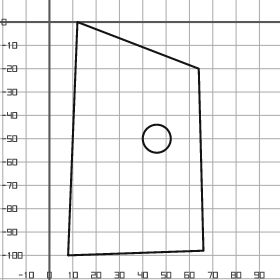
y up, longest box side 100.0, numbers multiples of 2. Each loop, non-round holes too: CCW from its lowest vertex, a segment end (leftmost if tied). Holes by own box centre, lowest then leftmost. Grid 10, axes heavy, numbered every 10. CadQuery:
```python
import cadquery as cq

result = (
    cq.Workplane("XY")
    .moveTo(8.0, -100.0)
    .lineTo(66.0, -98.0)
    .lineTo(64.0, -20.0)
    .lineTo(12.0, 0.0)
    .close()
    .moveTo(46.0, -50.0)
    .circle(6.0)
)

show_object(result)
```